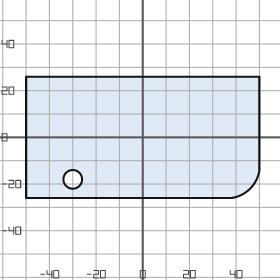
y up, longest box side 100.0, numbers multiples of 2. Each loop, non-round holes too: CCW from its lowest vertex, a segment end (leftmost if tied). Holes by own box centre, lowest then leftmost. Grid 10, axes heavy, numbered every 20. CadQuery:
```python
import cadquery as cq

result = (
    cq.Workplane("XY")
    .moveTo(-50.0, -26.0)
    .lineTo(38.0, -26.0)
    .threePointArc((46.0, -22.0), (50.0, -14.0))
    .lineTo(50.0, 26.0)
    .lineTo(-50.0, 26.0)
    .close()
    .moveTo(-30.0, -18.0)
    .circle(4.0)
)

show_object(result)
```